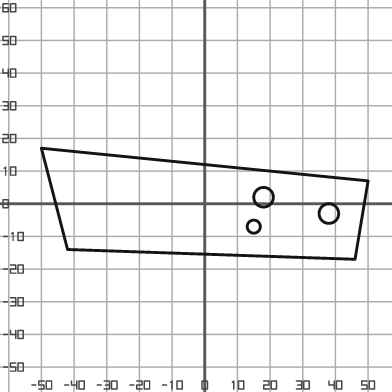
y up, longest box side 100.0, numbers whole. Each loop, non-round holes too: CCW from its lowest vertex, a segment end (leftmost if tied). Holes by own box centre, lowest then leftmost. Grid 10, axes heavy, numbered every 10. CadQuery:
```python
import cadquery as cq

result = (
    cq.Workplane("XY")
    .moveTo(46.0, -17.0)
    .lineTo(50.0, 7.0)
    .lineTo(-50.0, 17.0)
    .lineTo(-42.0, -14.0)
    .close()
    .moveTo(15.0, -7.0)
    .circle(2.0)
    .moveTo(38.0, -3.0)
    .circle(3.0)
    .moveTo(18.0, 2.0)
    .circle(3.0)
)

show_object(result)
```